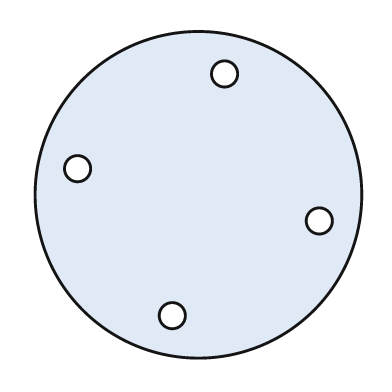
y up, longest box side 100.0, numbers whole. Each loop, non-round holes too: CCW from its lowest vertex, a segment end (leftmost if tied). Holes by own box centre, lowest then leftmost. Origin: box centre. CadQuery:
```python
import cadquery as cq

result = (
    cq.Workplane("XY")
    .moveTo(0.0, 0.0)
    .circle(50.0)
    .moveTo(-8.0, -37.0)
    .circle(4.0)
    .moveTo(37.0, -8.0)
    .circle(4.0)
    .moveTo(-37.0, 8.0)
    .circle(4.0)
    .moveTo(8.0, 37.0)
    .circle(4.0)
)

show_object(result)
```